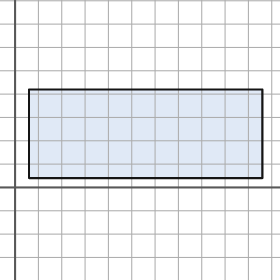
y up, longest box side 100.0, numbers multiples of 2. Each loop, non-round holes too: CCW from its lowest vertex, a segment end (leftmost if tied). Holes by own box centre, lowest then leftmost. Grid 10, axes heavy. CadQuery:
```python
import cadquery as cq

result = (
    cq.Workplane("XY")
    .moveTo(6.0, 4.0)
    .lineTo(106.0, 4.0)
    .lineTo(106.0, 42.0)
    .lineTo(6.0, 42.0)
    .close()
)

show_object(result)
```